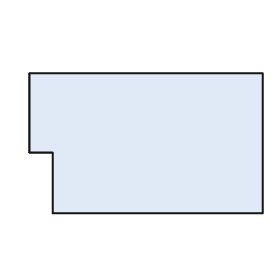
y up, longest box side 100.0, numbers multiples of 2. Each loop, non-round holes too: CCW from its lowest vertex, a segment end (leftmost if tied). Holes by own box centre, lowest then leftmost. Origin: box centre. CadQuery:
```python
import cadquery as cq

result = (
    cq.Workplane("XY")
    .moveTo(-40.0, -30.0)
    .lineTo(50.0, -30.0)
    .lineTo(50.0, 30.0)
    .lineTo(-50.0, 30.0)
    .lineTo(-50.0, -4.0)
    .lineTo(-40.0, -4.0)
    .close()
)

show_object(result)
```